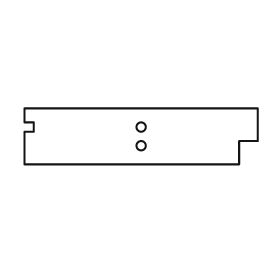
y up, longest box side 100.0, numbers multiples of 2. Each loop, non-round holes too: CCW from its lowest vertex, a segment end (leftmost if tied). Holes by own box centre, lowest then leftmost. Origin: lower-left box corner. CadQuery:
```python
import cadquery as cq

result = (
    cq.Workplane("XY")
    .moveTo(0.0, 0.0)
    .lineTo(92.0, 0.0)
    .lineTo(92.0, 10.0)
    .lineTo(100.0, 10.0)
    .lineTo(100.0, 24.0)
    .lineTo(0.0, 24.0)
    .lineTo(0.0, 18.0)
    .lineTo(4.0, 18.0)
    .lineTo(4.0, 14.0)
    .lineTo(0.0, 14.0)
    .close()
    .moveTo(50.0, 8.0)
    .circle(2.0)
    .moveTo(50.0, 16.0)
    .circle(2.0)
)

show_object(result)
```